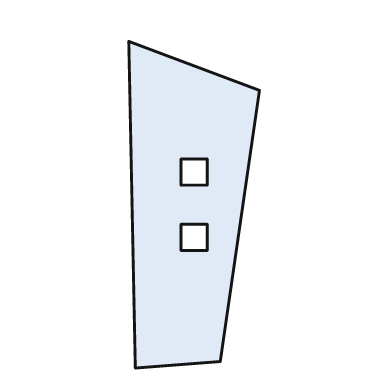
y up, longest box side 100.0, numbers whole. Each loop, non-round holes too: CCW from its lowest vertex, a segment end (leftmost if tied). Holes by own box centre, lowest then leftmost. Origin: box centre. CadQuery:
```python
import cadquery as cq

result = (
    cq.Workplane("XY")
    .moveTo(-18.0, -50.0)
    .lineTo(8.0, -48.0)
    .lineTo(20.0, 35.0)
    .lineTo(-20.0, 50.0)
    .close()
    .moveTo(-4.0, -14.0)
    .lineTo(4.0, -14.0)
    .lineTo(4.0, -6.0)
    .lineTo(-4.0, -6.0)
    .close()
    .moveTo(-4.0, 6.0)
    .lineTo(4.0, 6.0)
    .lineTo(4.0, 14.0)
    .lineTo(-4.0, 14.0)
    .close()
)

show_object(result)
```